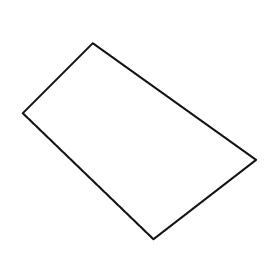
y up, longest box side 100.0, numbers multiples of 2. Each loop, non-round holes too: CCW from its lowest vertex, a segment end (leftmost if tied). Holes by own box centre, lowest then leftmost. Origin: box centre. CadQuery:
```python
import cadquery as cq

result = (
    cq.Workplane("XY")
    .moveTo(6.0, -42.0)
    .lineTo(50.0, -8.0)
    .lineTo(-20.0, 42.0)
    .lineTo(-50.0, 12.0)
    .close()
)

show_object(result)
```